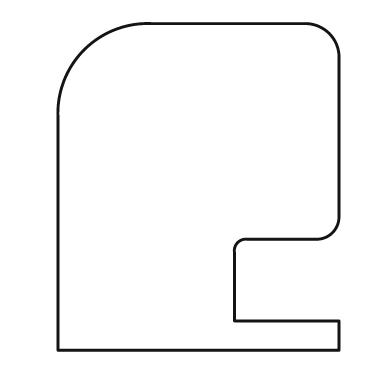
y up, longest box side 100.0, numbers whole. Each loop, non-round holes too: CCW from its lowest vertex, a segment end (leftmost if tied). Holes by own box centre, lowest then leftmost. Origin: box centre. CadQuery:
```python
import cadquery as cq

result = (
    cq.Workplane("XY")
    .moveTo(-43.0, -50.0)
    .lineTo(43.0, -50.0)
    .lineTo(43.0, -41.0)
    .lineTo(11.0, -41.0)
    .lineTo(11.0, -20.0)
    .threePointArc((12.0, -17.0), (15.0, -16.0))
    .lineTo(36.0, -16.0)
    .threePointArc((41.0, -14.0), (43.0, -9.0))
    .lineTo(43.0, 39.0)
    .threePointArc((40.0, 47.0), (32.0, 50.0))
    .lineTo(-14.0, 50.0)
    .threePointArc((-35.0, 42.0), (-43.0, 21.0))
    .close()
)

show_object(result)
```